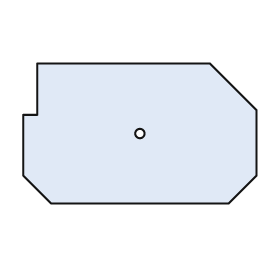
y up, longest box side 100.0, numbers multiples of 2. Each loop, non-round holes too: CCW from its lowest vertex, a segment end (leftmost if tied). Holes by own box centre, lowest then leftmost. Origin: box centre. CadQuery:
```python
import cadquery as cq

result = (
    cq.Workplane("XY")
    .moveTo(-38.0, -30.0)
    .lineTo(38.0, -30.0)
    .lineTo(50.0, -18.0)
    .lineTo(50.0, 10.0)
    .lineTo(30.0, 30.0)
    .lineTo(-44.0, 30.0)
    .lineTo(-44.0, 8.0)
    .lineTo(-50.0, 8.0)
    .lineTo(-50.0, -18.0)
    .close()
    .moveTo(0.0, 0.0)
    .circle(2.0)
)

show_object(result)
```